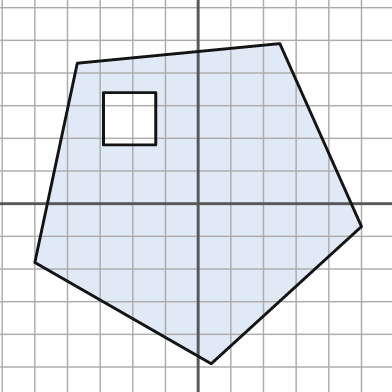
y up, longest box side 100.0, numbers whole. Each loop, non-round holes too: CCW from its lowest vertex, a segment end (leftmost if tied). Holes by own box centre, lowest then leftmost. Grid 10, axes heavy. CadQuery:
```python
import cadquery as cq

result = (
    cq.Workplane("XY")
    .moveTo(4.0, -49.0)
    .lineTo(50.0, -7.0)
    .lineTo(25.0, 49.0)
    .lineTo(-37.0, 43.0)
    .lineTo(-50.0, -18.0)
    .close()
    .moveTo(-29.0, 18.0)
    .lineTo(-13.0, 18.0)
    .lineTo(-13.0, 34.0)
    .lineTo(-29.0, 34.0)
    .close()
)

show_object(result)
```